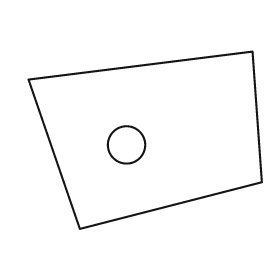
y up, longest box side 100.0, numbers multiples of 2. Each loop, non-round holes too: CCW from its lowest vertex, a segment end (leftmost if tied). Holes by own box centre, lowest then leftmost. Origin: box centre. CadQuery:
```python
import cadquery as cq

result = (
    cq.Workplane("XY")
    .moveTo(-28.0, -38.0)
    .lineTo(50.0, -18.0)
    .lineTo(46.0, 38.0)
    .lineTo(-50.0, 26.0)
    .close()
    .moveTo(-8.0, -2.0)
    .circle(8.0)
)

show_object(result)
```